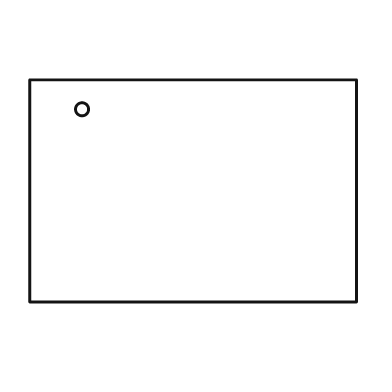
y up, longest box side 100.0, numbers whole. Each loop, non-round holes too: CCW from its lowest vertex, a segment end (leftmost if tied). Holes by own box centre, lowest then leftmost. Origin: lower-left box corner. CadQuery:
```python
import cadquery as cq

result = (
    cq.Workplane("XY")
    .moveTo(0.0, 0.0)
    .lineTo(100.0, 0.0)
    .lineTo(100.0, 68.0)
    .lineTo(0.0, 68.0)
    .close()
    .moveTo(16.0, 59.0)
    .circle(2.0)
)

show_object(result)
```